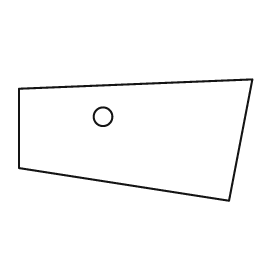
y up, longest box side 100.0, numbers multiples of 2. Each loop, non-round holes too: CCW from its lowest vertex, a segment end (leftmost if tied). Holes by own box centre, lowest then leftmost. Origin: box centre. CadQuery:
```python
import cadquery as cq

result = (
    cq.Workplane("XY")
    .moveTo(40.0, -26.0)
    .lineTo(50.0, 26.0)
    .lineTo(-50.0, 22.0)
    .lineTo(-50.0, -12.0)
    .close()
    .moveTo(-14.0, 10.0)
    .circle(4.0)
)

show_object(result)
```